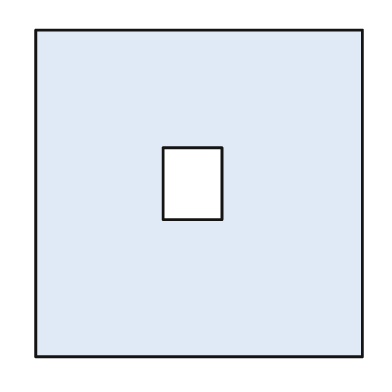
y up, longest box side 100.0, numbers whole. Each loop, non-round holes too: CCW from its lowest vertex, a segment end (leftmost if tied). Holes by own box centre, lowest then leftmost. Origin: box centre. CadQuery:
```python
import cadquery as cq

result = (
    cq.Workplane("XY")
    .moveTo(-50.0, -50.0)
    .lineTo(50.0, -50.0)
    .lineTo(50.0, 50.0)
    .lineTo(-50.0, 50.0)
    .close()
    .moveTo(-11.0, -8.0)
    .lineTo(7.0, -8.0)
    .lineTo(7.0, 14.0)
    .lineTo(-11.0, 14.0)
    .close()
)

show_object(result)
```